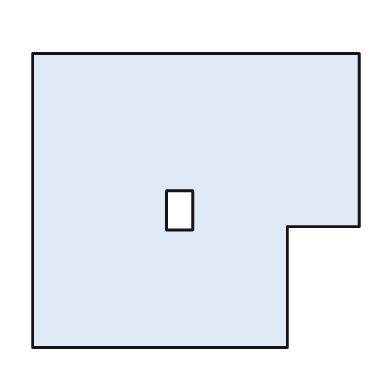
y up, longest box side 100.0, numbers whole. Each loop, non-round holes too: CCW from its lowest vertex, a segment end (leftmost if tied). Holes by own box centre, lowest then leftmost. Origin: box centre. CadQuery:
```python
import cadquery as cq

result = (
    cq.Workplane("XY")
    .moveTo(-50.0, -45.0)
    .lineTo(28.0, -45.0)
    .lineTo(28.0, -8.0)
    .lineTo(50.0, -8.0)
    .lineTo(50.0, 45.0)
    .lineTo(-50.0, 45.0)
    .close()
    .moveTo(-9.0, -9.0)
    .lineTo(-1.0, -9.0)
    .lineTo(-1.0, 3.0)
    .lineTo(-9.0, 3.0)
    .close()
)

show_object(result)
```